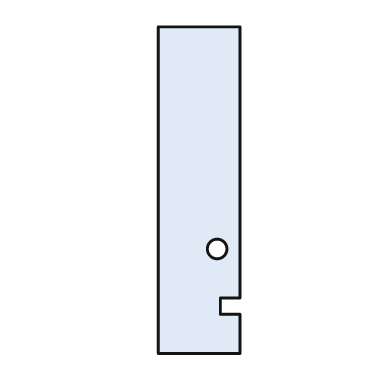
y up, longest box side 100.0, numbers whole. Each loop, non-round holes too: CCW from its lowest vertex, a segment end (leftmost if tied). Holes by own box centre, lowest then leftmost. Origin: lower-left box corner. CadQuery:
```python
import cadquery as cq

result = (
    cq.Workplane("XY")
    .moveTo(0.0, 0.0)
    .lineTo(25.0, 0.0)
    .lineTo(25.0, 12.0)
    .lineTo(19.0, 12.0)
    .lineTo(19.0, 17.0)
    .lineTo(25.0, 17.0)
    .lineTo(25.0, 100.0)
    .lineTo(0.0, 100.0)
    .close()
    .moveTo(18.0, 32.0)
    .circle(3.0)
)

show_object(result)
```